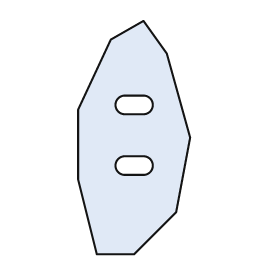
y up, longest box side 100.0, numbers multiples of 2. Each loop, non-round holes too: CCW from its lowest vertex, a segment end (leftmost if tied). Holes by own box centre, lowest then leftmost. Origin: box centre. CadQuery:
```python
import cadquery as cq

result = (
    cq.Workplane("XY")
    .moveTo(-16.0, -50.0)
    .lineTo(0.0, -50.0)
    .lineTo(18.0, -32.0)
    .lineTo(24.0, 0.0)
    .lineTo(14.0, 36.0)
    .lineTo(4.0, 50.0)
    .lineTo(-10.0, 42.0)
    .lineTo(-24.0, 12.0)
    .lineTo(-24.0, -18.0)
    .close()
    .moveTo(-4.0, -16.0)
    .lineTo(4.0, -16.0)
    .threePointArc((8.0, -12.0), (4.0, -8.0))
    .lineTo(-4.0, -8.0)
    .threePointArc((-8.0, -12.0), (-4.0, -16.0))
    .close()
    .moveTo(-4.0, 10.0)
    .lineTo(4.0, 10.0)
    .threePointArc((8.0, 14.0), (4.0, 18.0))
    .lineTo(-4.0, 18.0)
    .threePointArc((-8.0, 14.0), (-4.0, 10.0))
    .close()
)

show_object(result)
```